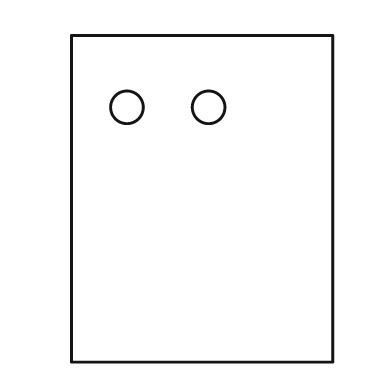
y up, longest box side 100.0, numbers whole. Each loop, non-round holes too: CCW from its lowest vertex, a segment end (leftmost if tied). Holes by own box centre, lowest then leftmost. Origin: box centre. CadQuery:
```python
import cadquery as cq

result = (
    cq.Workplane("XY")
    .moveTo(-40.0, -50.0)
    .lineTo(40.0, -50.0)
    .lineTo(40.0, 50.0)
    .lineTo(-40.0, 50.0)
    .close()
    .moveTo(-23.0, 28.0)
    .circle(5.0)
    .moveTo(2.0, 28.0)
    .circle(5.0)
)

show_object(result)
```